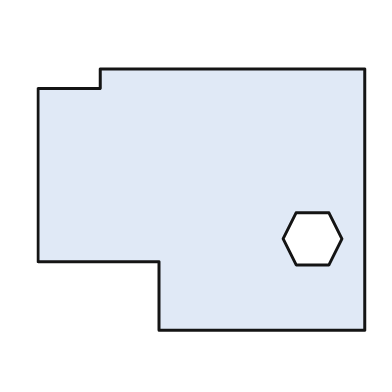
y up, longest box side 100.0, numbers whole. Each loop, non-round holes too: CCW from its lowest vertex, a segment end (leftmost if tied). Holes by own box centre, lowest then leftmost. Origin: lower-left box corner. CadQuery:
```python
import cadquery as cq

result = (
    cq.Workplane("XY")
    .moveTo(37.0, 0.0)
    .lineTo(100.0, 0.0)
    .lineTo(100.0, 80.0)
    .lineTo(19.0, 80.0)
    .lineTo(19.0, 74.0)
    .lineTo(0.0, 74.0)
    .lineTo(0.0, 21.0)
    .lineTo(37.0, 21.0)
    .close()
    .moveTo(79.0, 20.0)
    .lineTo(89.0, 20.0)
    .lineTo(93.0, 28.0)
    .lineTo(89.0, 36.0)
    .lineTo(79.0, 36.0)
    .lineTo(75.0, 28.0)
    .close()
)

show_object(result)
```